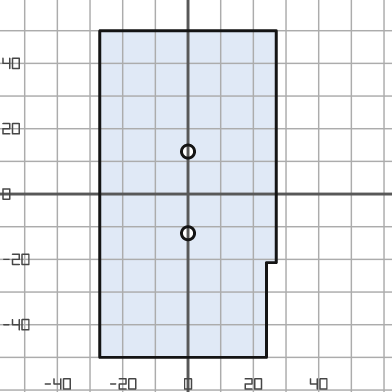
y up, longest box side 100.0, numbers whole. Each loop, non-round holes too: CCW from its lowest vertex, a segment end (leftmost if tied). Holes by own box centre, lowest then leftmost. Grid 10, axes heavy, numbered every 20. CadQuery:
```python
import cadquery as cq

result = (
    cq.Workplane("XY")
    .moveTo(-27.0, -50.0)
    .lineTo(24.0, -50.0)
    .lineTo(24.0, -21.0)
    .lineTo(27.0, -21.0)
    .lineTo(27.0, 50.0)
    .lineTo(-27.0, 50.0)
    .close()
    .moveTo(0.0, -12.0)
    .circle(2.0)
    .moveTo(0.0, 13.0)
    .circle(2.0)
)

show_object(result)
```